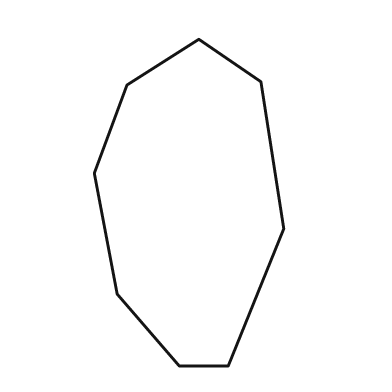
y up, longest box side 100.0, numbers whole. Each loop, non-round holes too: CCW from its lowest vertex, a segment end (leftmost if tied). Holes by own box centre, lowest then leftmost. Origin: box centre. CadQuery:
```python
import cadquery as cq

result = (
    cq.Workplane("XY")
    .moveTo(-3.0, -50.0)
    .lineTo(12.0, -50.0)
    .lineTo(29.0, -8.0)
    .lineTo(22.0, 37.0)
    .lineTo(3.0, 50.0)
    .lineTo(-19.0, 36.0)
    .lineTo(-29.0, 9.0)
    .lineTo(-22.0, -28.0)
    .close()
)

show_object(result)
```